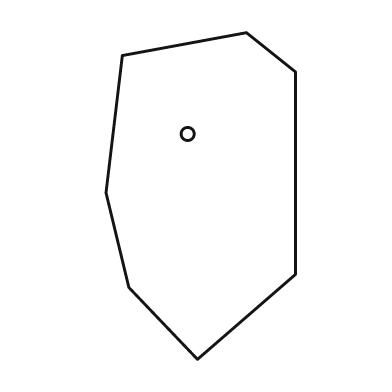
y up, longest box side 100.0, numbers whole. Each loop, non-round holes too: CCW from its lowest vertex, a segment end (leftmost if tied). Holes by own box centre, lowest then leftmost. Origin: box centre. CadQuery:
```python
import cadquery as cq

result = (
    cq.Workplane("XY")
    .moveTo(-1.0, -50.0)
    .lineTo(29.0, -24.0)
    .lineTo(29.0, 38.0)
    .lineTo(14.0, 50.0)
    .lineTo(-24.0, 43.0)
    .lineTo(-29.0, 1.0)
    .lineTo(-22.0, -28.0)
    .close()
    .moveTo(-4.0, 19.0)
    .circle(2.0)
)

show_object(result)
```